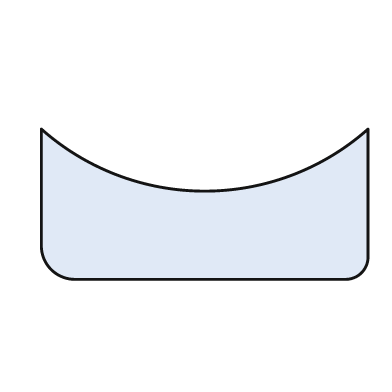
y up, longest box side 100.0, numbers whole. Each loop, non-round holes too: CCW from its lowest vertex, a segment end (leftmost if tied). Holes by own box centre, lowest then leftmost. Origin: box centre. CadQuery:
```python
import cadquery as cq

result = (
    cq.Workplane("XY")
    .moveTo(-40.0, -23.0)
    .lineTo(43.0, -23.0)
    .threePointArc((48.0, -21.0), (50.0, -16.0))
    .lineTo(50.0, 23.0)
    .threePointArc((0.0, 4.0), (-50.0, 23.0))
    .lineTo(-50.0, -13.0)
    .threePointArc((-47.0, -20.0), (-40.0, -23.0))
    .close()
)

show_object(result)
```